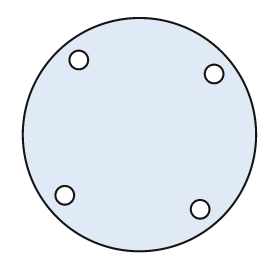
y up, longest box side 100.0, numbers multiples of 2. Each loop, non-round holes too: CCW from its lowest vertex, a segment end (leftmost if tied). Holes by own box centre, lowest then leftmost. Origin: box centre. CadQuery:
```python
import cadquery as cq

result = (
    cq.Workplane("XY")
    .moveTo(0.0, 0.0)
    .circle(50.0)
    .moveTo(26.0, -32.0)
    .circle(4.0)
    .moveTo(-32.0, -26.0)
    .circle(4.0)
    .moveTo(32.0, 26.0)
    .circle(4.0)
    .moveTo(-26.0, 32.0)
    .circle(4.0)
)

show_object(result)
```